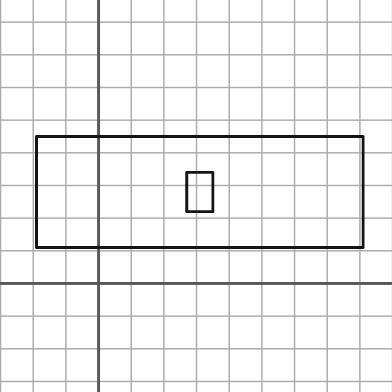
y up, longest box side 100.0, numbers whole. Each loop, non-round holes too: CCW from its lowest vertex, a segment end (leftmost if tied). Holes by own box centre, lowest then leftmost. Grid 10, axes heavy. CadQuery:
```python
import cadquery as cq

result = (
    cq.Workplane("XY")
    .moveTo(-19.0, 11.0)
    .lineTo(81.0, 11.0)
    .lineTo(81.0, 45.0)
    .lineTo(-19.0, 45.0)
    .close()
    .moveTo(27.0, 22.0)
    .lineTo(35.0, 22.0)
    .lineTo(35.0, 34.0)
    .lineTo(27.0, 34.0)
    .close()
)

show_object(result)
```